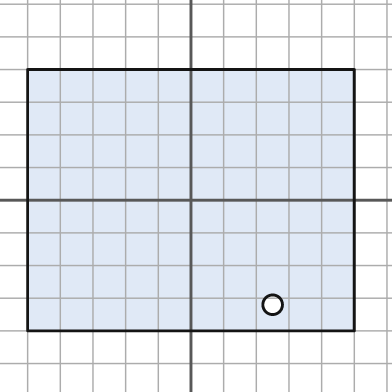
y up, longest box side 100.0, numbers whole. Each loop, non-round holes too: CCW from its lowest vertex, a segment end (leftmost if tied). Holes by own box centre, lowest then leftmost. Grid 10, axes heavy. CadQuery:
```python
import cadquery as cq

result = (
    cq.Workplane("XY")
    .moveTo(-50.0, -40.0)
    .lineTo(50.0, -40.0)
    .lineTo(50.0, 40.0)
    .lineTo(-50.0, 40.0)
    .close()
    .moveTo(25.0, -32.0)
    .circle(3.0)
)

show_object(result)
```